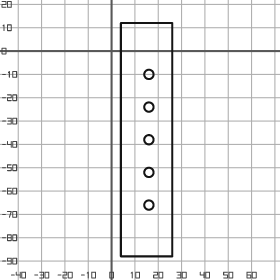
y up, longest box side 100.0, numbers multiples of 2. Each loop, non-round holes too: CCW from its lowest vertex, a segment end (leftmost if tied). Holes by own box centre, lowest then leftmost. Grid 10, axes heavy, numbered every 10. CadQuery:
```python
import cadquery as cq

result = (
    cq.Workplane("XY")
    .moveTo(4.0, -88.0)
    .lineTo(26.0, -88.0)
    .lineTo(26.0, 12.0)
    .lineTo(4.0, 12.0)
    .close()
    .moveTo(16.0, -66.0)
    .circle(2.0)
    .moveTo(16.0, -52.0)
    .circle(2.0)
    .moveTo(16.0, -38.0)
    .circle(2.0)
    .moveTo(16.0, -24.0)
    .circle(2.0)
    .moveTo(16.0, -10.0)
    .circle(2.0)
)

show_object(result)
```